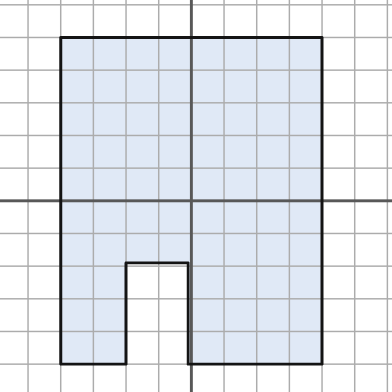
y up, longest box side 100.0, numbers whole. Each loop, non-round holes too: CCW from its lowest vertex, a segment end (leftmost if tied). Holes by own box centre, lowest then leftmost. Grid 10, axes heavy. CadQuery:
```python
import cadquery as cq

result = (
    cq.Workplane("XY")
    .moveTo(-40.0, -50.0)
    .lineTo(-20.0, -50.0)
    .lineTo(-20.0, -19.0)
    .lineTo(-1.0, -19.0)
    .lineTo(-1.0, -50.0)
    .lineTo(40.0, -50.0)
    .lineTo(40.0, 50.0)
    .lineTo(-40.0, 50.0)
    .close()
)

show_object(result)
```